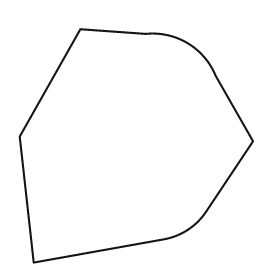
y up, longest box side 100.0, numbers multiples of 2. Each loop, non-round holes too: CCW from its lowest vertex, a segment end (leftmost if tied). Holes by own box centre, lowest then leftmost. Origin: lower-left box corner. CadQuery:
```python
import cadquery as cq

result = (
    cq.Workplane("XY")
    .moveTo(6.0, 0.0)
    .lineTo(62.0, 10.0)
    .threePointArc((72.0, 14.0), (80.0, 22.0))
    .lineTo(100.0, 52.0)
    .lineTo(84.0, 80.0)
    .threePointArc((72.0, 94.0), (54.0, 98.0))
    .lineTo(26.0, 100.0)
    .lineTo(0.0, 54.0)
    .close()
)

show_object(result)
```